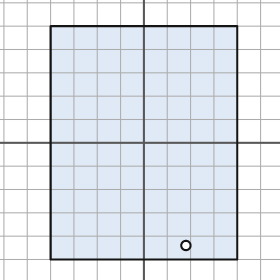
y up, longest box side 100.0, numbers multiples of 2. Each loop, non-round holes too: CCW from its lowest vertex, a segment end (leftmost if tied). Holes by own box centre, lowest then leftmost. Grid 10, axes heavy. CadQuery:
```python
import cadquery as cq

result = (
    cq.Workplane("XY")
    .moveTo(-40.0, -50.0)
    .lineTo(40.0, -50.0)
    .lineTo(40.0, 50.0)
    .lineTo(-40.0, 50.0)
    .close()
    .moveTo(18.0, -44.0)
    .circle(2.0)
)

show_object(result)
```